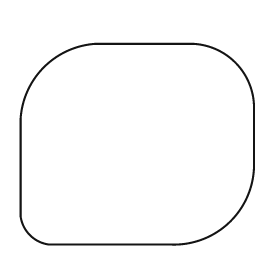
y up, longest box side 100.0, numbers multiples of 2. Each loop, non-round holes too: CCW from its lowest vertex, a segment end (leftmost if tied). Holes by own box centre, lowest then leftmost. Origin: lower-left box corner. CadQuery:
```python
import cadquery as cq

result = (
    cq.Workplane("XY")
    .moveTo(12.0, 0.0)
    .lineTo(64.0, 0.0)
    .threePointArc((90.0, 10.0), (100.0, 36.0))
    .lineTo(100.0, 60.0)
    .threePointArc((92.0, 78.0), (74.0, 86.0))
    .lineTo(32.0, 86.0)
    .threePointArc((10.0, 76.0), (0.0, 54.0))
    .lineTo(0.0, 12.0)
    .threePointArc((4.0, 4.0), (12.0, 0.0))
    .close()
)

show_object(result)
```